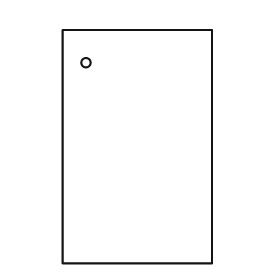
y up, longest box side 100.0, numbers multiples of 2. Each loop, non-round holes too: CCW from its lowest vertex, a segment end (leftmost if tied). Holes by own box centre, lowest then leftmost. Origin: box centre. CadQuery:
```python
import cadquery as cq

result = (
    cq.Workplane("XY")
    .moveTo(-32.0, -50.0)
    .lineTo(32.0, -50.0)
    .lineTo(32.0, 50.0)
    .lineTo(-32.0, 50.0)
    .close()
    .moveTo(-22.0, 36.0)
    .circle(2.0)
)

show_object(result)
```